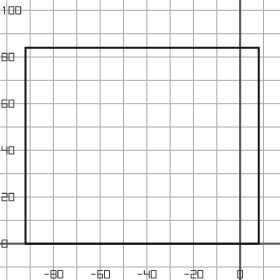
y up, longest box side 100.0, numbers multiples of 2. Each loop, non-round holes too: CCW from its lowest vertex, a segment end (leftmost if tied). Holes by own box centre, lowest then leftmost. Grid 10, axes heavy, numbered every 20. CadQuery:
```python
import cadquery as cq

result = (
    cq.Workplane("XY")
    .moveTo(-92.0, 0.0)
    .lineTo(8.0, 0.0)
    .lineTo(8.0, 84.0)
    .lineTo(-92.0, 84.0)
    .close()
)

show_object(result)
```